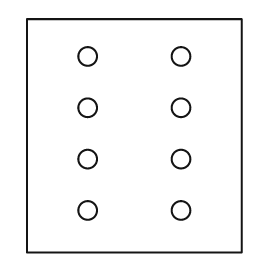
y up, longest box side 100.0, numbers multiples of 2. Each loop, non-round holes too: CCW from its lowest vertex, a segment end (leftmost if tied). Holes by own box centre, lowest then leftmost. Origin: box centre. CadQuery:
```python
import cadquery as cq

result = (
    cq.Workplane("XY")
    .moveTo(-46.0, -50.0)
    .lineTo(46.0, -50.0)
    .lineTo(46.0, 50.0)
    .lineTo(-46.0, 50.0)
    .close()
    .moveTo(-20.0, -32.0)
    .circle(4.0)
    .moveTo(20.0, -32.0)
    .circle(4.0)
    .moveTo(-20.0, -10.0)
    .circle(4.0)
    .moveTo(20.0, -10.0)
    .circle(4.0)
    .moveTo(-20.0, 12.0)
    .circle(4.0)
    .moveTo(20.0, 12.0)
    .circle(4.0)
    .moveTo(-20.0, 34.0)
    .circle(4.0)
    .moveTo(20.0, 34.0)
    .circle(4.0)
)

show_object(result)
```